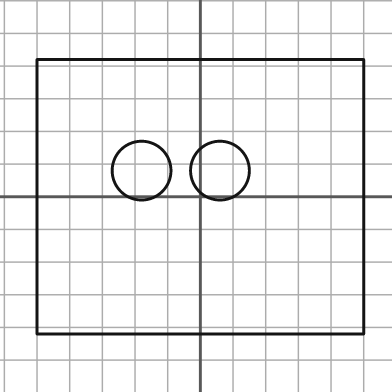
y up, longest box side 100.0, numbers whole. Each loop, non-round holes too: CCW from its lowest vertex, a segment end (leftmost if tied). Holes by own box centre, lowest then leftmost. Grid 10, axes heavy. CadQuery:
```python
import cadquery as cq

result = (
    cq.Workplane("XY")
    .moveTo(-50.0, -42.0)
    .lineTo(50.0, -42.0)
    .lineTo(50.0, 42.0)
    .lineTo(-50.0, 42.0)
    .close()
    .moveTo(-18.0, 8.0)
    .circle(9.0)
    .moveTo(6.0, 8.0)
    .circle(9.0)
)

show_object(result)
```